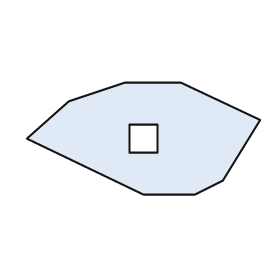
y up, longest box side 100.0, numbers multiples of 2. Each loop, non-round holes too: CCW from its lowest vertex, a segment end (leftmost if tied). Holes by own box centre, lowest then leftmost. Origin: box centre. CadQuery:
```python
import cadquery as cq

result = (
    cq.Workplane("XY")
    .moveTo(0.0, -24.0)
    .lineTo(22.0, -24.0)
    .lineTo(34.0, -18.0)
    .lineTo(50.0, 8.0)
    .lineTo(16.0, 24.0)
    .lineTo(-8.0, 24.0)
    .lineTo(-32.0, 16.0)
    .lineTo(-50.0, 0.0)
    .close()
    .moveTo(-6.0, -6.0)
    .lineTo(6.0, -6.0)
    .lineTo(6.0, 6.0)
    .lineTo(-6.0, 6.0)
    .close()
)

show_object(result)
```